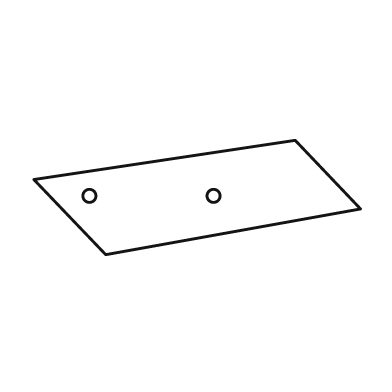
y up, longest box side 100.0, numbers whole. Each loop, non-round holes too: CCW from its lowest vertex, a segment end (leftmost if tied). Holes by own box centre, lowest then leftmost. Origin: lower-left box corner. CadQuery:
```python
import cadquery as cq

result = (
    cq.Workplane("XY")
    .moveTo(22.0, 0.0)
    .lineTo(100.0, 14.0)
    .lineTo(80.0, 35.0)
    .lineTo(0.0, 23.0)
    .close()
    .moveTo(17.0, 18.0)
    .circle(2.0)
    .moveTo(55.0, 18.0)
    .circle(2.0)
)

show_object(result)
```